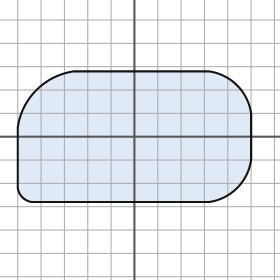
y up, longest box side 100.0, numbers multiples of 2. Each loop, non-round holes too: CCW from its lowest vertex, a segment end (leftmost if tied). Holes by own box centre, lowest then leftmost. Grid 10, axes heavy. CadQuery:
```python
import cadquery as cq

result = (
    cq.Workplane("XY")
    .moveTo(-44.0, -28.0)
    .lineTo(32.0, -28.0)
    .threePointArc((44.0, -22.0), (50.0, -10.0))
    .lineTo(50.0, 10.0)
    .threePointArc((44.0, 22.0), (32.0, 28.0))
    .lineTo(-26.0, 28.0)
    .threePointArc((-42.0, 20.0), (-50.0, 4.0))
    .lineTo(-50.0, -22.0)
    .threePointArc((-48.0, -26.0), (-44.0, -28.0))
    .close()
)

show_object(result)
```